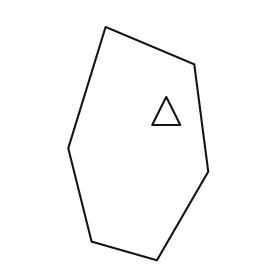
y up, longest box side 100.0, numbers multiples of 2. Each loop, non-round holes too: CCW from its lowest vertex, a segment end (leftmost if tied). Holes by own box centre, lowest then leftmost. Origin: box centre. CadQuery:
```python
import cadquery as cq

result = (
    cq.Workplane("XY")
    .moveTo(8.0, -50.0)
    .lineTo(30.0, -12.0)
    .lineTo(24.0, 34.0)
    .lineTo(-14.0, 50.0)
    .lineTo(-30.0, -2.0)
    .lineTo(-20.0, -42.0)
    .close()
    .moveTo(6.0, 8.0)
    .lineTo(18.0, 8.0)
    .lineTo(12.0, 20.0)
    .close()
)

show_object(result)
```